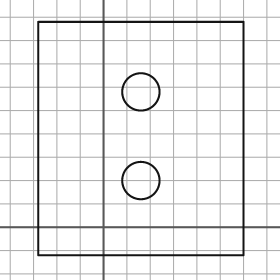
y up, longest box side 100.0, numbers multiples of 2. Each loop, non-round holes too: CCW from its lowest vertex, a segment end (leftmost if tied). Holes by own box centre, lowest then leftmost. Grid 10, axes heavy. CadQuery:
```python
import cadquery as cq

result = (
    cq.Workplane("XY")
    .moveTo(-28.0, -12.0)
    .lineTo(60.0, -12.0)
    .lineTo(60.0, 88.0)
    .lineTo(-28.0, 88.0)
    .close()
    .moveTo(16.0, 20.0)
    .circle(8.0)
    .moveTo(16.0, 58.0)
    .circle(8.0)
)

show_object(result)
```